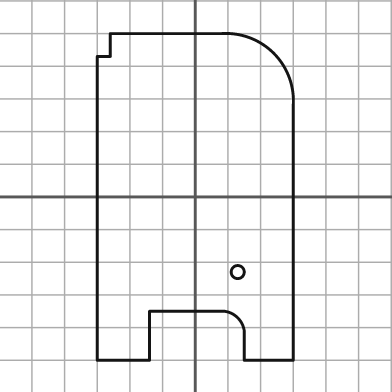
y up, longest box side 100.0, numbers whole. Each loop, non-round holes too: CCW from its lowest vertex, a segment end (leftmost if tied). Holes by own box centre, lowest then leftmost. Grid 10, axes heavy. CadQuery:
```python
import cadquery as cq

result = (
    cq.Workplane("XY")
    .moveTo(-30.0, -50.0)
    .lineTo(-14.0, -50.0)
    .lineTo(-14.0, -35.0)
    .lineTo(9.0, -35.0)
    .threePointArc((13.0, -37.0), (15.0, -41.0))
    .lineTo(15.0, -50.0)
    .lineTo(30.0, -50.0)
    .lineTo(30.0, 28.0)
    .threePointArc((24.0, 44.0), (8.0, 50.0))
    .lineTo(-26.0, 50.0)
    .lineTo(-26.0, 43.0)
    .lineTo(-30.0, 43.0)
    .close()
    .moveTo(13.0, -23.0)
    .circle(2.0)
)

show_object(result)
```